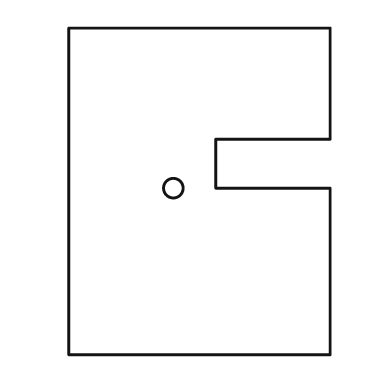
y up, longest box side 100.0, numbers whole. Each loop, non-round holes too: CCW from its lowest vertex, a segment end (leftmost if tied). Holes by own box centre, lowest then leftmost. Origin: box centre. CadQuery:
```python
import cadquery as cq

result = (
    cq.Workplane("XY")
    .moveTo(-40.0, -50.0)
    .lineTo(40.0, -50.0)
    .lineTo(40.0, 1.0)
    .lineTo(5.0, 1.0)
    .lineTo(5.0, 16.0)
    .lineTo(40.0, 16.0)
    .lineTo(40.0, 50.0)
    .lineTo(-40.0, 50.0)
    .close()
    .moveTo(-8.0, 1.0)
    .circle(3.0)
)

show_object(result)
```